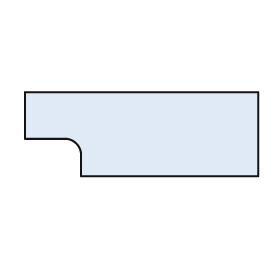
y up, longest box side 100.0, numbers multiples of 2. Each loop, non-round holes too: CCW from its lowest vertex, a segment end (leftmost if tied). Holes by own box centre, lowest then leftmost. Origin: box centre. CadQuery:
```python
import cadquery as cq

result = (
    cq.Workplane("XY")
    .moveTo(-26.0, -18.0)
    .lineTo(50.0, -18.0)
    .lineTo(50.0, 18.0)
    .lineTo(-50.0, 18.0)
    .lineTo(-50.0, -2.0)
    .lineTo(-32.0, -2.0)
    .threePointArc((-28.0, -4.0), (-26.0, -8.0))
    .close()
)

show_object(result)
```